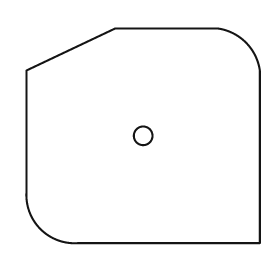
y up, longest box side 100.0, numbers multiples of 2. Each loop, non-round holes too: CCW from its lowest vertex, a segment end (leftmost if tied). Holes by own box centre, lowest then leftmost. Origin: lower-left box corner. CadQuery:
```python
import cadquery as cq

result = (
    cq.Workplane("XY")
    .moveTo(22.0, 0.0)
    .lineTo(100.0, 0.0)
    .lineTo(100.0, 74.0)
    .threePointArc((94.0, 86.0), (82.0, 92.0))
    .lineTo(38.0, 92.0)
    .lineTo(0.0, 74.0)
    .lineTo(0.0, 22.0)
    .threePointArc((6.0, 6.0), (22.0, 0.0))
    .close()
    .moveTo(50.0, 46.0)
    .circle(4.0)
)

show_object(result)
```